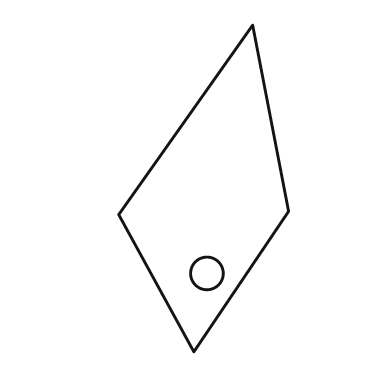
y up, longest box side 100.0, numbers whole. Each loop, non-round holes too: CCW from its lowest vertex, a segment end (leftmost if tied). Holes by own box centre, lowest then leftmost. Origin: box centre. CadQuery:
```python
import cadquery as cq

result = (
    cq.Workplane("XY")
    .moveTo(-3.0, -50.0)
    .lineTo(26.0, -7.0)
    .lineTo(15.0, 50.0)
    .lineTo(-26.0, -8.0)
    .close()
    .moveTo(1.0, -26.0)
    .circle(5.0)
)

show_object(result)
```